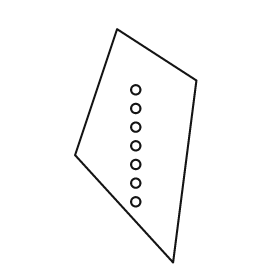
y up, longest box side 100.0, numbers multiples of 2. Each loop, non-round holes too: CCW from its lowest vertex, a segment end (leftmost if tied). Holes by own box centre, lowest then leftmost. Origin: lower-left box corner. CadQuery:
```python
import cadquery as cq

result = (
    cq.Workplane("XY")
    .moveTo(42.0, 0.0)
    .lineTo(52.0, 78.0)
    .lineTo(18.0, 100.0)
    .lineTo(0.0, 46.0)
    .close()
    .moveTo(26.0, 26.0)
    .circle(2.0)
    .moveTo(26.0, 34.0)
    .circle(2.0)
    .moveTo(26.0, 42.0)
    .circle(2.0)
    .moveTo(26.0, 50.0)
    .circle(2.0)
    .moveTo(26.0, 58.0)
    .circle(2.0)
    .moveTo(26.0, 66.0)
    .circle(2.0)
    .moveTo(26.0, 74.0)
    .circle(2.0)
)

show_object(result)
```